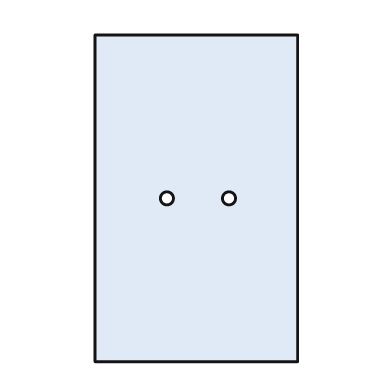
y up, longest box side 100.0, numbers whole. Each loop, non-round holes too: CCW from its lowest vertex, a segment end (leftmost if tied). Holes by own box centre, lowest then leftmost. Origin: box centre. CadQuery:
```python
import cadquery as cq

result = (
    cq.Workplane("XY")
    .moveTo(-31.0, -50.0)
    .lineTo(31.0, -50.0)
    .lineTo(31.0, 50.0)
    .lineTo(-31.0, 50.0)
    .close()
    .moveTo(-9.0, 0.0)
    .circle(2.0)
    .moveTo(10.0, 0.0)
    .circle(2.0)
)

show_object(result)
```